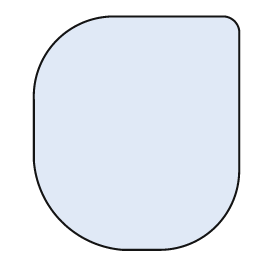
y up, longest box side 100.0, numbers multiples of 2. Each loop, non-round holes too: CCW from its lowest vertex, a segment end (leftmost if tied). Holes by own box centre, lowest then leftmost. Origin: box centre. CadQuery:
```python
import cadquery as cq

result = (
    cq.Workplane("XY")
    .moveTo(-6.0, -50.0)
    .lineTo(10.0, -50.0)
    .threePointArc((34.0, -40.0), (44.0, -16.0))
    .lineTo(44.0, 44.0)
    .threePointArc((42.0, 48.0), (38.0, 50.0))
    .lineTo(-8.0, 50.0)
    .threePointArc((-34.0, 40.0), (-44.0, 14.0))
    .lineTo(-44.0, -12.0)
    .threePointArc((-32.0, -38.0), (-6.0, -50.0))
    .close()
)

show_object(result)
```